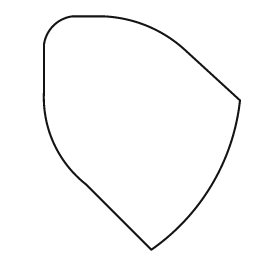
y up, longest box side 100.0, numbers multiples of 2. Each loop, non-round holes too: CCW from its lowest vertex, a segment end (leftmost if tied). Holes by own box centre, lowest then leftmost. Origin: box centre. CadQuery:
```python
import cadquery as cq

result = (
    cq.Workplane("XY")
    .moveTo(4.0, -50.0)
    .threePointArc((30.0, -22.0), (42.0, 14.0))
    .lineTo(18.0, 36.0)
    .threePointArc((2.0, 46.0), (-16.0, 50.0))
    .lineTo(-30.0, 50.0)
    .threePointArc((-38.0, 46.0), (-42.0, 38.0))
    .lineTo(-42.0, 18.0)
    .threePointArc((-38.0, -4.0), (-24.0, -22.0))
    .close()
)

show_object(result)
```